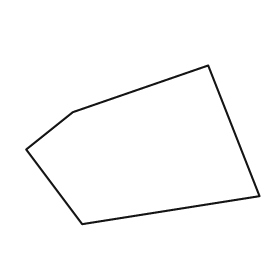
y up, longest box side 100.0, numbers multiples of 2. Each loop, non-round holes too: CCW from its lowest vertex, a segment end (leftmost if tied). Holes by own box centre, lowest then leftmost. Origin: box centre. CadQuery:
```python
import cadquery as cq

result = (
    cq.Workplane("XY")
    .moveTo(-26.0, -34.0)
    .lineTo(50.0, -22.0)
    .lineTo(28.0, 34.0)
    .lineTo(-30.0, 14.0)
    .lineTo(-50.0, -2.0)
    .close()
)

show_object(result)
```